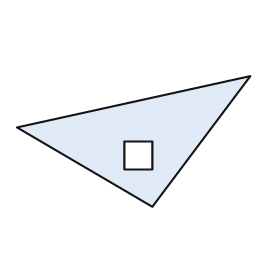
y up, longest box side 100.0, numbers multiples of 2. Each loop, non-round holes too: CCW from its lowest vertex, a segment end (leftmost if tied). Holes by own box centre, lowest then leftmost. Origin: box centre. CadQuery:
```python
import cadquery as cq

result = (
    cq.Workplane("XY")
    .moveTo(8.0, -28.0)
    .lineTo(50.0, 28.0)
    .lineTo(-50.0, 6.0)
    .close()
    .moveTo(-4.0, -12.0)
    .lineTo(8.0, -12.0)
    .lineTo(8.0, 0.0)
    .lineTo(-4.0, 0.0)
    .close()
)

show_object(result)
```